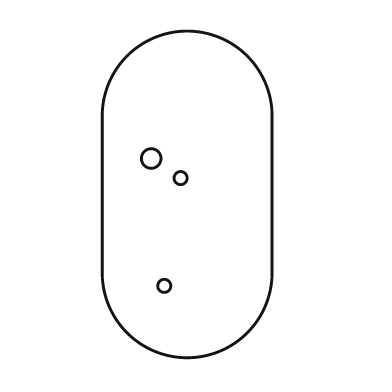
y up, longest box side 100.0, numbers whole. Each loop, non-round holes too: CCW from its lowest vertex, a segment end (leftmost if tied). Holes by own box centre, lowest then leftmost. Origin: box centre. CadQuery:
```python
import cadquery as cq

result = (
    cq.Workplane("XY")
    .moveTo(-26.0, -24.0)
    .threePointArc((0.0, -50.0), (26.0, -24.0))
    .lineTo(26.0, 24.0)
    .threePointArc((0.0, 50.0), (-26.0, 24.0))
    .close()
    .moveTo(-7.0, -28.0)
    .circle(2.0)
    .moveTo(-2.0, 5.0)
    .circle(2.0)
    .moveTo(-11.0, 11.0)
    .circle(3.0)
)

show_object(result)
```